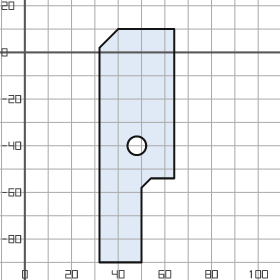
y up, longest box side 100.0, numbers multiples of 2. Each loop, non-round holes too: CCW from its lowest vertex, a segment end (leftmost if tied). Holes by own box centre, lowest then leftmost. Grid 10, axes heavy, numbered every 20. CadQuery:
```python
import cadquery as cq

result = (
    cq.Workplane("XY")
    .moveTo(32.0, -90.0)
    .lineTo(50.0, -90.0)
    .lineTo(50.0, -58.0)
    .lineTo(54.0, -54.0)
    .lineTo(64.0, -54.0)
    .lineTo(64.0, 10.0)
    .lineTo(40.0, 10.0)
    .lineTo(32.0, 2.0)
    .close()
    .moveTo(48.0, -40.0)
    .circle(4.0)
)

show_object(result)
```